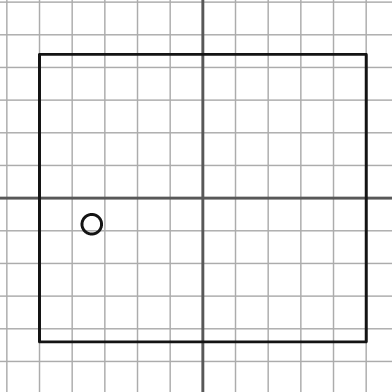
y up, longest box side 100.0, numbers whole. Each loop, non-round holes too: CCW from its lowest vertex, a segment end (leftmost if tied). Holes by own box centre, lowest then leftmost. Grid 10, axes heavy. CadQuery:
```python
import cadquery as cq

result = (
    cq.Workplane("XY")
    .moveTo(-50.0, -44.0)
    .lineTo(50.0, -44.0)
    .lineTo(50.0, 44.0)
    .lineTo(-50.0, 44.0)
    .close()
    .moveTo(-34.0, -8.0)
    .circle(3.0)
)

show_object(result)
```